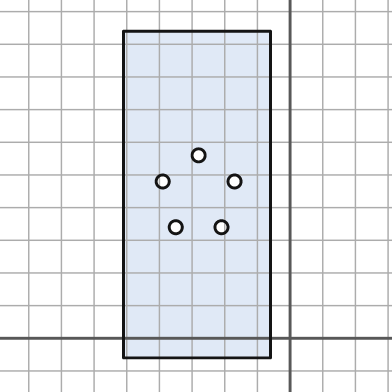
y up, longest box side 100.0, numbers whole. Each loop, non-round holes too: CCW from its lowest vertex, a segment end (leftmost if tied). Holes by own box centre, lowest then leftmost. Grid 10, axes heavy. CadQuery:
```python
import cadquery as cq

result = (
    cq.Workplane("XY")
    .moveTo(-51.0, -6.0)
    .lineTo(-6.0, -6.0)
    .lineTo(-6.0, 94.0)
    .lineTo(-51.0, 94.0)
    .close()
    .moveTo(-35.0, 34.0)
    .circle(2.0)
    .moveTo(-21.0, 34.0)
    .circle(2.0)
    .moveTo(-39.0, 48.0)
    .circle(2.0)
    .moveTo(-17.0, 48.0)
    .circle(2.0)
    .moveTo(-28.0, 56.0)
    .circle(2.0)
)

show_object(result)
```